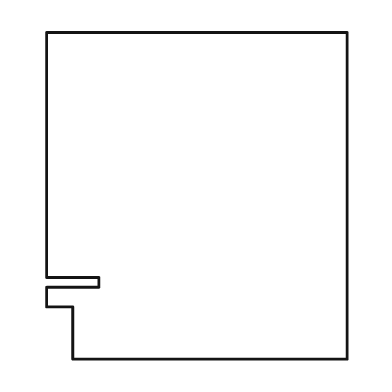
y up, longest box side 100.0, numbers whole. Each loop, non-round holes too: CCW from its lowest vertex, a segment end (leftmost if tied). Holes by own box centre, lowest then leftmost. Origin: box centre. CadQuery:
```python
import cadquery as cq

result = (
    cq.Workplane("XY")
    .moveTo(-38.0, -50.0)
    .lineTo(46.0, -50.0)
    .lineTo(46.0, 50.0)
    .lineTo(-46.0, 50.0)
    .lineTo(-46.0, -25.0)
    .lineTo(-30.0, -25.0)
    .lineTo(-30.0, -28.0)
    .lineTo(-46.0, -28.0)
    .lineTo(-46.0, -34.0)
    .lineTo(-38.0, -34.0)
    .close()
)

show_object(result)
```